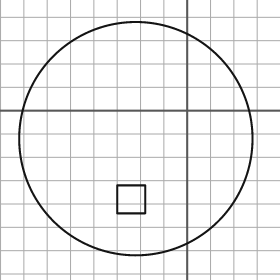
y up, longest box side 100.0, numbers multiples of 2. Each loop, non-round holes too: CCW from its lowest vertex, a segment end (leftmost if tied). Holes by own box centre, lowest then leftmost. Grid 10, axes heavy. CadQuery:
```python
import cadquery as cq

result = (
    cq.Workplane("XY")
    .moveTo(-22.0, -12.0)
    .circle(50.0)
    .moveTo(-30.0, -44.0)
    .lineTo(-18.0, -44.0)
    .lineTo(-18.0, -32.0)
    .lineTo(-30.0, -32.0)
    .close()
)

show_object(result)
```